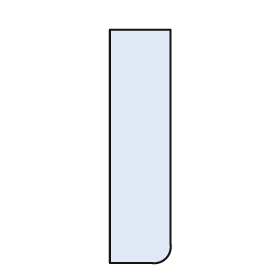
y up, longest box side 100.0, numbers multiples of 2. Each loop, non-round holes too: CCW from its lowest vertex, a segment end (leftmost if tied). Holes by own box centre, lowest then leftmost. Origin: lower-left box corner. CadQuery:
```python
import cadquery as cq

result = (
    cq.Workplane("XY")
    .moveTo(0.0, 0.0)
    .lineTo(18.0, 0.0)
    .threePointArc((24.0, 2.0), (26.0, 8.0))
    .lineTo(26.0, 100.0)
    .lineTo(0.0, 100.0)
    .close()
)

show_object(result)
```